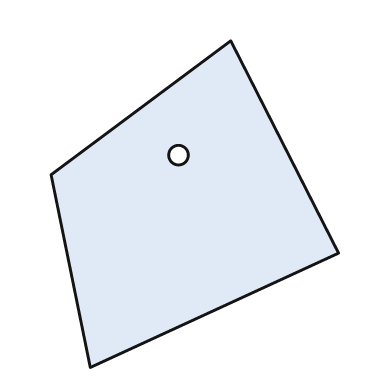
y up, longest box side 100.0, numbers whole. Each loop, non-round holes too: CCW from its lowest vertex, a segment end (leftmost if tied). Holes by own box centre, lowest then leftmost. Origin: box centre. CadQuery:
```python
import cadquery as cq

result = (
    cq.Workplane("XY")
    .moveTo(-32.0, -50.0)
    .lineTo(44.0, -15.0)
    .lineTo(11.0, 50.0)
    .lineTo(-44.0, 9.0)
    .close()
    .moveTo(-5.0, 15.0)
    .circle(3.0)
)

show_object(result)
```